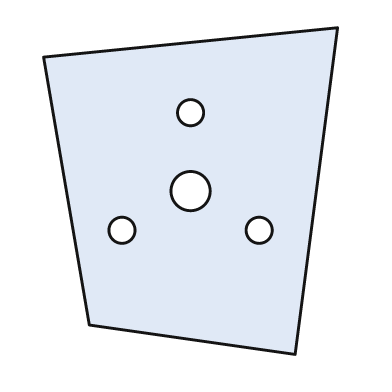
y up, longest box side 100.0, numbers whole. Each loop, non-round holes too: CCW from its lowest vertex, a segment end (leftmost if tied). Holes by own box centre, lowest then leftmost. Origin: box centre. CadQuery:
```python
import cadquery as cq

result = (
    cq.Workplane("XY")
    .moveTo(32.0, -50.0)
    .lineTo(45.0, 50.0)
    .lineTo(-45.0, 41.0)
    .lineTo(-31.0, -41.0)
    .close()
    .moveTo(-21.0, -12.0)
    .circle(4.0)
    .moveTo(21.0, -12.0)
    .circle(4.0)
    .moveTo(0.0, 0.0)
    .circle(6.0)
    .moveTo(0.0, 24.0)
    .circle(4.0)
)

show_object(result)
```